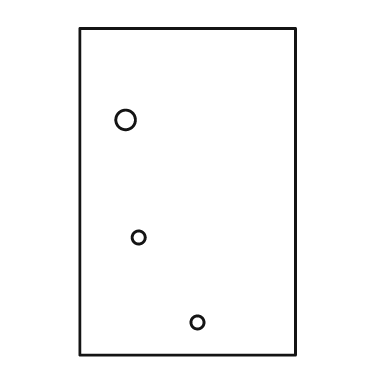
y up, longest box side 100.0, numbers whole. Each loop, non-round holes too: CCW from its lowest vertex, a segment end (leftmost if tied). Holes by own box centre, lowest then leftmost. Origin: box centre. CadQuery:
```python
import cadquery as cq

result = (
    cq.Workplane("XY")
    .moveTo(-33.0, -50.0)
    .lineTo(33.0, -50.0)
    .lineTo(33.0, 50.0)
    .lineTo(-33.0, 50.0)
    .close()
    .moveTo(3.0, -40.0)
    .circle(2.0)
    .moveTo(-15.0, -14.0)
    .circle(2.0)
    .moveTo(-19.0, 22.0)
    .circle(3.0)
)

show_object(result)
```